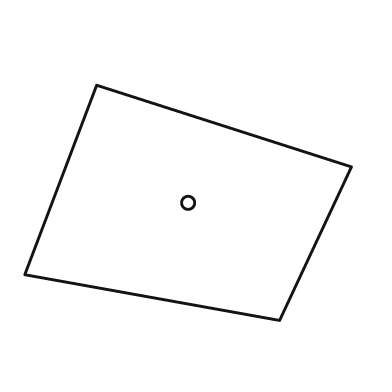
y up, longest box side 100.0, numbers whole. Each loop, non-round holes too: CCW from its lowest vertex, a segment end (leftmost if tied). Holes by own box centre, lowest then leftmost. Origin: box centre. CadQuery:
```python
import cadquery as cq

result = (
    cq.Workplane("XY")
    .moveTo(28.0, -36.0)
    .lineTo(50.0, 11.0)
    .lineTo(-28.0, 36.0)
    .lineTo(-50.0, -22.0)
    .close()
    .moveTo(0.0, 0.0)
    .circle(2.0)
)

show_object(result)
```